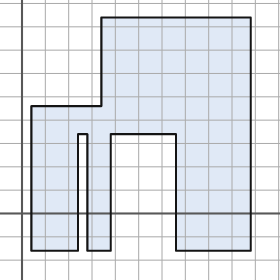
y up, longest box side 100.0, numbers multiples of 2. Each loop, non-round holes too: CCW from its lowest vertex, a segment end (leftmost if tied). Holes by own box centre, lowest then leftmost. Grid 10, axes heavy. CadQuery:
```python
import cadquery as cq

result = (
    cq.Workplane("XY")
    .moveTo(4.0, -16.0)
    .lineTo(24.0, -16.0)
    .lineTo(24.0, 34.0)
    .lineTo(28.0, 34.0)
    .lineTo(28.0, -16.0)
    .lineTo(38.0, -16.0)
    .lineTo(38.0, 34.0)
    .lineTo(66.0, 34.0)
    .lineTo(66.0, -16.0)
    .lineTo(98.0, -16.0)
    .lineTo(98.0, 84.0)
    .lineTo(34.0, 84.0)
    .lineTo(34.0, 46.0)
    .lineTo(4.0, 46.0)
    .close()
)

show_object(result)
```